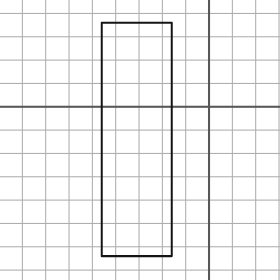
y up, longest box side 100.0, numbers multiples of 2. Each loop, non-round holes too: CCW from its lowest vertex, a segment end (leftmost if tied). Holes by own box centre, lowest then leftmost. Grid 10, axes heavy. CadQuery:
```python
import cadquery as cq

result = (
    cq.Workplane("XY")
    .moveTo(-46.0, -64.0)
    .lineTo(-16.0, -64.0)
    .lineTo(-16.0, 36.0)
    .lineTo(-46.0, 36.0)
    .close()
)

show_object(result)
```